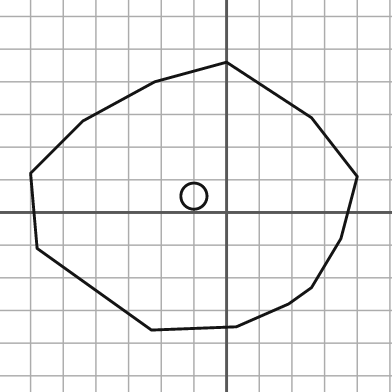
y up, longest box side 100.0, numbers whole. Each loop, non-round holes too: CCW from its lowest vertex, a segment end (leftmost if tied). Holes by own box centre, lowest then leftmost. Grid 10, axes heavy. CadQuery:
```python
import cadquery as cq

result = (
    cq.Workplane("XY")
    .moveTo(-23.0, -36.0)
    .lineTo(3.0, -35.0)
    .lineTo(19.0, -28.0)
    .lineTo(26.0, -23.0)
    .lineTo(35.0, -8.0)
    .lineTo(40.0, 11.0)
    .lineTo(26.0, 29.0)
    .lineTo(0.0, 46.0)
    .lineTo(-22.0, 40.0)
    .lineTo(-44.0, 28.0)
    .lineTo(-60.0, 12.0)
    .lineTo(-58.0, -11.0)
    .close()
    .moveTo(-10.0, 5.0)
    .circle(4.0)
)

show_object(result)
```